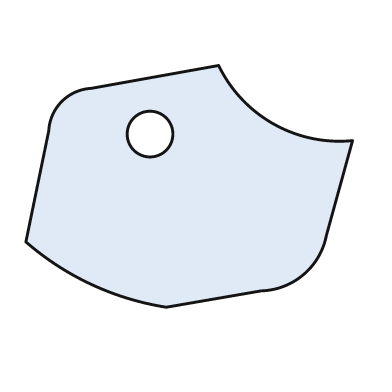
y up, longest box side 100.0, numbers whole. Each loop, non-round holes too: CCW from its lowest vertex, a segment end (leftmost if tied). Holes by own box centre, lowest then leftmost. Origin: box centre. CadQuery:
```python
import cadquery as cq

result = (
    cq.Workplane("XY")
    .moveTo(-7.0, -37.0)
    .lineTo(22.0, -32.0)
    .threePointArc((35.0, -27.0), (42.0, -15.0))
    .lineTo(50.0, 14.0)
    .threePointArc((26.0, 19.0), (9.0, 37.0))
    .lineTo(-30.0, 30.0)
    .threePointArc((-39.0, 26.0), (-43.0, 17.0))
    .lineTo(-50.0, -17.0)
    .threePointArc((-30.0, -30.0), (-7.0, -37.0))
    .close()
    .moveTo(-12.0, 16.0)
    .circle(7.0)
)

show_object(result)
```